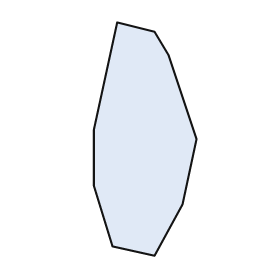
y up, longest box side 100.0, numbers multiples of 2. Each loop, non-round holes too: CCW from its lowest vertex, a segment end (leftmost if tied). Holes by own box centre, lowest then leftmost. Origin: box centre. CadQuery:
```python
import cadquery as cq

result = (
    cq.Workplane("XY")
    .moveTo(4.0, -50.0)
    .lineTo(16.0, -28.0)
    .lineTo(22.0, 0.0)
    .lineTo(10.0, 36.0)
    .lineTo(4.0, 46.0)
    .lineTo(-12.0, 50.0)
    .lineTo(-22.0, 4.0)
    .lineTo(-22.0, -20.0)
    .lineTo(-14.0, -46.0)
    .close()
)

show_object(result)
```